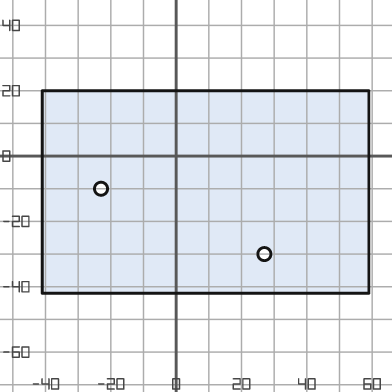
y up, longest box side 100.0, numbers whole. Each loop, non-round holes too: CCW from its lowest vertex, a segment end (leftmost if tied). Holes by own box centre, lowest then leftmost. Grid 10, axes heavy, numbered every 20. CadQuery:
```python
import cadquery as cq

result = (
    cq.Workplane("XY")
    .moveTo(-41.0, -42.0)
    .lineTo(59.0, -42.0)
    .lineTo(59.0, 20.0)
    .lineTo(-41.0, 20.0)
    .close()
    .moveTo(27.0, -30.0)
    .circle(2.0)
    .moveTo(-23.0, -10.0)
    .circle(2.0)
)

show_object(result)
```